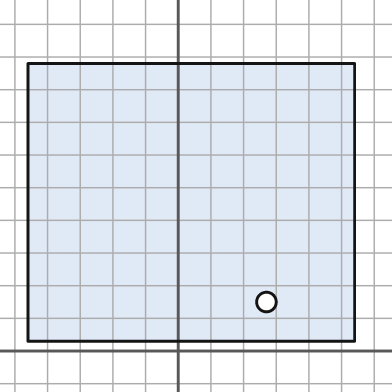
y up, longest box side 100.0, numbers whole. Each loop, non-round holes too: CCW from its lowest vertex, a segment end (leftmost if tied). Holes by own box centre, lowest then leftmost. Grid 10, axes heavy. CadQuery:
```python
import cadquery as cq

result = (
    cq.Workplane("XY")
    .moveTo(-46.0, 3.0)
    .lineTo(54.0, 3.0)
    .lineTo(54.0, 88.0)
    .lineTo(-46.0, 88.0)
    .close()
    .moveTo(27.0, 15.0)
    .circle(3.0)
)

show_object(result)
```